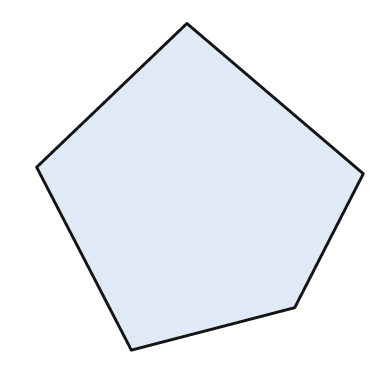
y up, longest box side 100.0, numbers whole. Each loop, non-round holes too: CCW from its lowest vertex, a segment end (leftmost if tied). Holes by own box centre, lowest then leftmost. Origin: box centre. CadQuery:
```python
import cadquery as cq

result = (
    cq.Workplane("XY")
    .moveTo(-21.0, -50.0)
    .lineTo(29.0, -37.0)
    .lineTo(50.0, 4.0)
    .lineTo(-4.0, 50.0)
    .lineTo(-50.0, 6.0)
    .close()
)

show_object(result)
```